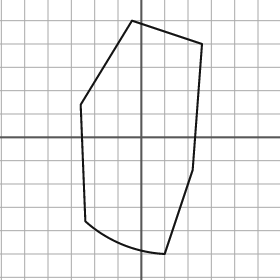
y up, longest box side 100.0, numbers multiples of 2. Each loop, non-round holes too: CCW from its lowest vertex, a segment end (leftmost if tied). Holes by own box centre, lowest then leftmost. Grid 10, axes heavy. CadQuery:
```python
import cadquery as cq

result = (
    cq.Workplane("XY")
    .moveTo(10.0, -50.0)
    .lineTo(22.0, -14.0)
    .lineTo(26.0, 40.0)
    .lineTo(-4.0, 50.0)
    .lineTo(-26.0, 14.0)
    .lineTo(-24.0, -36.0)
    .threePointArc((-8.0, -46.0), (10.0, -50.0))
    .close()
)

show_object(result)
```